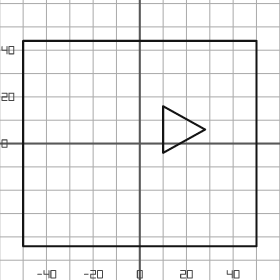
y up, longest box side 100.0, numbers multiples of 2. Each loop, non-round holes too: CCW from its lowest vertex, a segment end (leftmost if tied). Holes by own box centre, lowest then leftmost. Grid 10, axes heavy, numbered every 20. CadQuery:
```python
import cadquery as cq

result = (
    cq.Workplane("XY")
    .moveTo(-50.0, -44.0)
    .lineTo(50.0, -44.0)
    .lineTo(50.0, 44.0)
    .lineTo(-50.0, 44.0)
    .close()
    .moveTo(10.0, -4.0)
    .lineTo(28.0, 6.0)
    .lineTo(10.0, 16.0)
    .close()
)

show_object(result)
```